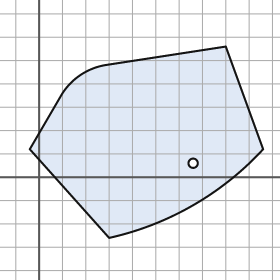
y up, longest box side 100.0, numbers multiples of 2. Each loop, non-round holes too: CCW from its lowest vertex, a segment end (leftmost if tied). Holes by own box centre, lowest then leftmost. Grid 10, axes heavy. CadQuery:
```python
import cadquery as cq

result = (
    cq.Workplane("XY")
    .moveTo(30.0, -26.0)
    .threePointArc((66.0, -12.0), (96.0, 12.0))
    .lineTo(80.0, 56.0)
    .lineTo(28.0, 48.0)
    .threePointArc((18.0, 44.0), (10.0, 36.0))
    .lineTo(-4.0, 12.0)
    .close()
    .moveTo(66.0, 6.0)
    .circle(2.0)
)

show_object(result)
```